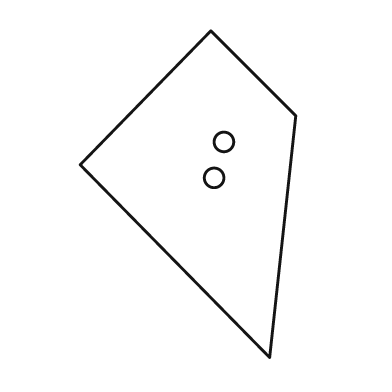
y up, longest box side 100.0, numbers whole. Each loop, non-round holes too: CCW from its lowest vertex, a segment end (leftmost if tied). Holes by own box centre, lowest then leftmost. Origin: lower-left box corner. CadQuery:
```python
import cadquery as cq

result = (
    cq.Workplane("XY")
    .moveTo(58.0, 0.0)
    .lineTo(66.0, 74.0)
    .lineTo(40.0, 100.0)
    .lineTo(0.0, 59.0)
    .close()
    .moveTo(41.0, 55.0)
    .circle(3.0)
    .moveTo(44.0, 66.0)
    .circle(3.0)
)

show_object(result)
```